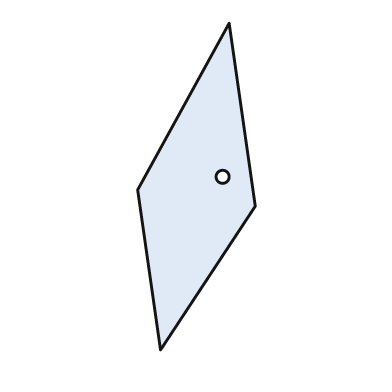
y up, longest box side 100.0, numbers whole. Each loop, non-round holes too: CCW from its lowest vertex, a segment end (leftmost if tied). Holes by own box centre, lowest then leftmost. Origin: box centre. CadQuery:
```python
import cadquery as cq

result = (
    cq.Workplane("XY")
    .moveTo(-11.0, -50.0)
    .lineTo(18.0, -6.0)
    .lineTo(10.0, 50.0)
    .lineTo(-18.0, -1.0)
    .close()
    .moveTo(8.0, 3.0)
    .circle(2.0)
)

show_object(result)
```